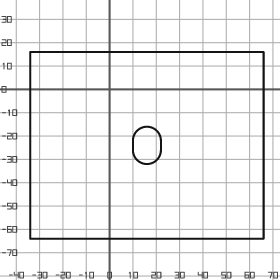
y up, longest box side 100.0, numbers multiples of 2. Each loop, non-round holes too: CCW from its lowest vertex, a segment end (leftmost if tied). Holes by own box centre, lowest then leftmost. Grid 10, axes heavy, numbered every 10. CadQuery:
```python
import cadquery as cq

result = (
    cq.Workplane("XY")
    .moveTo(-34.0, -64.0)
    .lineTo(66.0, -64.0)
    .lineTo(66.0, 16.0)
    .lineTo(-34.0, 16.0)
    .close()
    .moveTo(10.0, -26.0)
    .threePointArc((16.0, -32.0), (22.0, -26.0))
    .lineTo(22.0, -22.0)
    .threePointArc((16.0, -16.0), (10.0, -22.0))
    .close()
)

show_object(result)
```